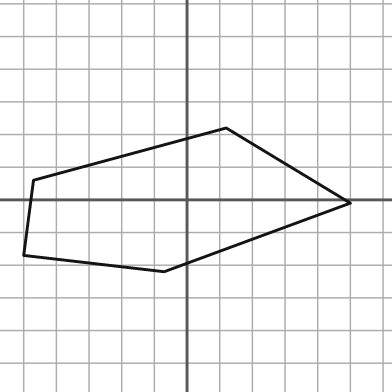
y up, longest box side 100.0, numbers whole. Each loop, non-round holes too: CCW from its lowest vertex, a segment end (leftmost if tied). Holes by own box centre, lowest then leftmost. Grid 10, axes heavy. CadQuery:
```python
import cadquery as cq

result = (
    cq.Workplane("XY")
    .moveTo(-7.0, -22.0)
    .lineTo(50.0, -1.0)
    .lineTo(12.0, 22.0)
    .lineTo(-47.0, 6.0)
    .lineTo(-50.0, -17.0)
    .close()
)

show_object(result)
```